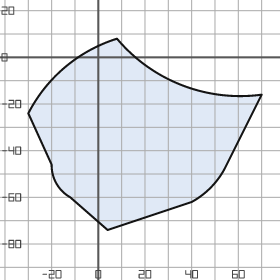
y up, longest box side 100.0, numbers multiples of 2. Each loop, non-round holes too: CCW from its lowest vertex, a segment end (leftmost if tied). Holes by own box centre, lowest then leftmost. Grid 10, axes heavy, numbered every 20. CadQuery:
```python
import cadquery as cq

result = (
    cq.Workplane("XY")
    .moveTo(4.0, -74.0)
    .lineTo(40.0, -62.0)
    .threePointArc((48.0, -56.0), (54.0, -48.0))
    .lineTo(70.0, -16.0)
    .threePointArc((36.0, -12.0), (8.0, 8.0))
    .threePointArc((-14.0, -4.0), (-30.0, -24.0))
    .lineTo(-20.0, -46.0)
    .threePointArc((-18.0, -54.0), (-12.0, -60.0))
    .close()
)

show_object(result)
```